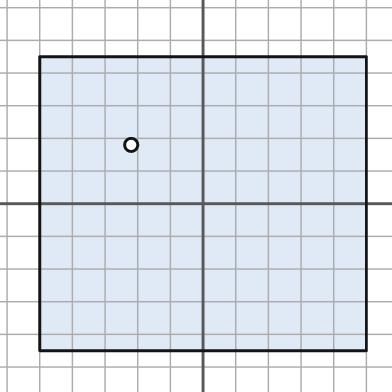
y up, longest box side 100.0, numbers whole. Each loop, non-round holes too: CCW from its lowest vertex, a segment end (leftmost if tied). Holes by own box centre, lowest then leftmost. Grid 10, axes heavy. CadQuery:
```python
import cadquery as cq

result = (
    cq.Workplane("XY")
    .moveTo(-50.0, -45.0)
    .lineTo(50.0, -45.0)
    .lineTo(50.0, 45.0)
    .lineTo(-50.0, 45.0)
    .close()
    .moveTo(-22.0, 18.0)
    .circle(2.0)
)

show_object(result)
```